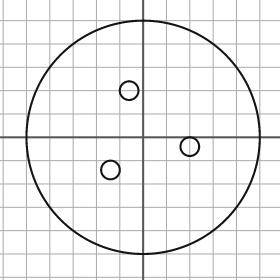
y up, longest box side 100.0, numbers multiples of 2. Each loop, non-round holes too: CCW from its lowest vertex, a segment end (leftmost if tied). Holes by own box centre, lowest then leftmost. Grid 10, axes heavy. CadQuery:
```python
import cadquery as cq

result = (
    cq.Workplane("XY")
    .moveTo(0.0, 0.0)
    .circle(50.0)
    .moveTo(-14.0, -14.0)
    .circle(4.0)
    .moveTo(20.0, -4.0)
    .circle(4.0)
    .moveTo(-6.0, 20.0)
    .circle(4.0)
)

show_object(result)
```